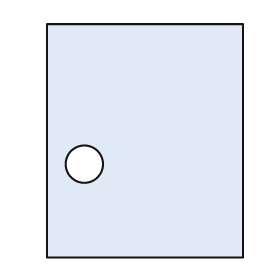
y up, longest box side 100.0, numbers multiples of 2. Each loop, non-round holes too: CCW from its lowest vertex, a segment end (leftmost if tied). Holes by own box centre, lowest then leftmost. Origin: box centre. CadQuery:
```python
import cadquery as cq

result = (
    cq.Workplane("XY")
    .moveTo(-42.0, -50.0)
    .lineTo(42.0, -50.0)
    .lineTo(42.0, 50.0)
    .lineTo(-42.0, 50.0)
    .close()
    .moveTo(-26.0, -10.0)
    .circle(8.0)
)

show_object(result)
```